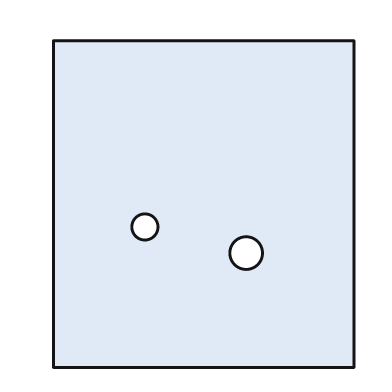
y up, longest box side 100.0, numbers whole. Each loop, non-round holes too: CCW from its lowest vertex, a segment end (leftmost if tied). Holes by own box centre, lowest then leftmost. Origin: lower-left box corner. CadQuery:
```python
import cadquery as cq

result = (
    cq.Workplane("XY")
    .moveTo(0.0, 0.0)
    .lineTo(92.0, 0.0)
    .lineTo(92.0, 100.0)
    .lineTo(0.0, 100.0)
    .close()
    .moveTo(59.0, 35.0)
    .circle(5.0)
    .moveTo(28.0, 43.0)
    .circle(4.0)
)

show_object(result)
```